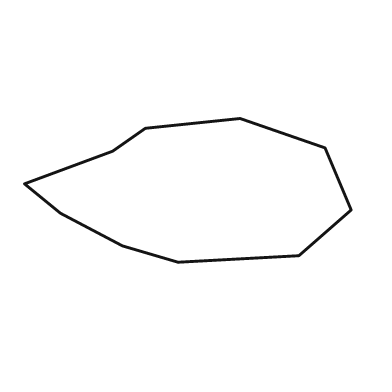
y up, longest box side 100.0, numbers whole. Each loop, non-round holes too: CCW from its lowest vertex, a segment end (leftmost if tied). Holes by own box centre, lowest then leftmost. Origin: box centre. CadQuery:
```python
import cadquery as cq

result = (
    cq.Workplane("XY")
    .moveTo(-3.0, -22.0)
    .lineTo(34.0, -20.0)
    .lineTo(50.0, -6.0)
    .lineTo(42.0, 13.0)
    .lineTo(16.0, 22.0)
    .lineTo(-13.0, 19.0)
    .lineTo(-23.0, 12.0)
    .lineTo(-50.0, 2.0)
    .lineTo(-39.0, -7.0)
    .lineTo(-20.0, -17.0)
    .close()
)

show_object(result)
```